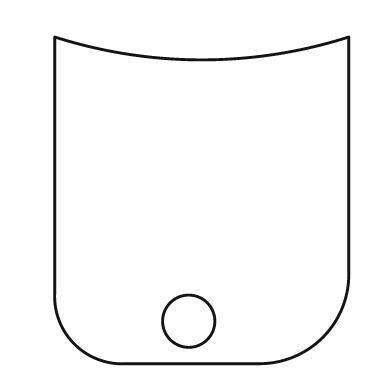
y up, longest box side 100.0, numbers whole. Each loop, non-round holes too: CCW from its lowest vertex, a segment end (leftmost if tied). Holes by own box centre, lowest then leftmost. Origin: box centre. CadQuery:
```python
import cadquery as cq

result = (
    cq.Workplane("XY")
    .moveTo(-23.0, -50.0)
    .lineTo(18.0, -50.0)
    .threePointArc((37.0, -42.0), (45.0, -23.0))
    .lineTo(45.0, 50.0)
    .threePointArc((0.0, 43.0), (-45.0, 50.0))
    .lineTo(-45.0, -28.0)
    .threePointArc((-39.0, -44.0), (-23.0, -50.0))
    .close()
    .moveTo(-4.0, -37.0)
    .circle(8.0)
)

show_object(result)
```